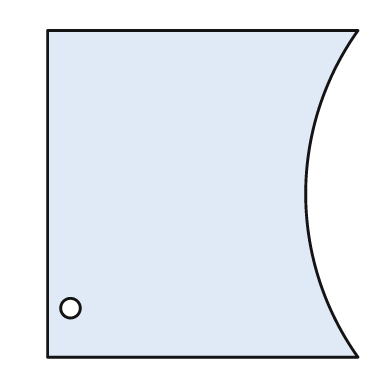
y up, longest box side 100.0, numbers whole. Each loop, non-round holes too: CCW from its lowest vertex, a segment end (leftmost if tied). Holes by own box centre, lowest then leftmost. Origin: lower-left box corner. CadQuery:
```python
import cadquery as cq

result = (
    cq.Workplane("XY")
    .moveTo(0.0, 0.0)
    .lineTo(95.0, 0.0)
    .threePointArc((79.0, 50.0), (95.0, 100.0))
    .lineTo(0.0, 100.0)
    .close()
    .moveTo(7.0, 15.0)
    .circle(3.0)
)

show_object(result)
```